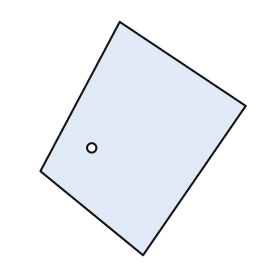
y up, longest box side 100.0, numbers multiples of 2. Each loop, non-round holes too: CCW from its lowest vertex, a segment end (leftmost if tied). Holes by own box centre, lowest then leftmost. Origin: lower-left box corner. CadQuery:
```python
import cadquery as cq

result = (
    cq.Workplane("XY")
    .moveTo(44.0, 0.0)
    .lineTo(88.0, 64.0)
    .lineTo(34.0, 100.0)
    .lineTo(0.0, 36.0)
    .close()
    .moveTo(22.0, 46.0)
    .circle(2.0)
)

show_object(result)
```